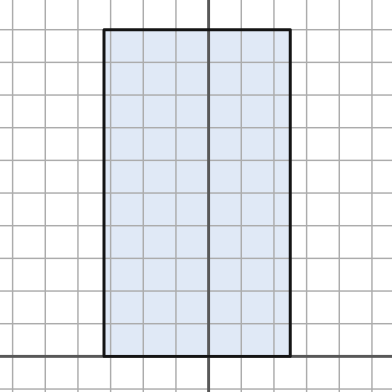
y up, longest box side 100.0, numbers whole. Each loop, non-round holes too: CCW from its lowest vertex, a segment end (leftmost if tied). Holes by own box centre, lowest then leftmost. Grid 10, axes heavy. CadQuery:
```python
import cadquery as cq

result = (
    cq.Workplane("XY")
    .moveTo(-32.0, 0.0)
    .lineTo(25.0, 0.0)
    .lineTo(25.0, 100.0)
    .lineTo(-32.0, 100.0)
    .close()
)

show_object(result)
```